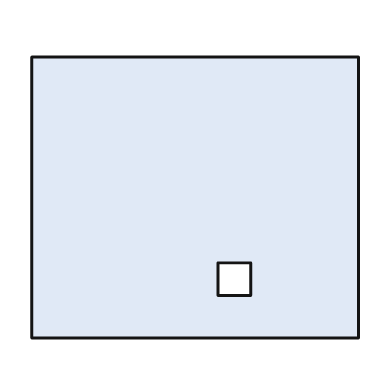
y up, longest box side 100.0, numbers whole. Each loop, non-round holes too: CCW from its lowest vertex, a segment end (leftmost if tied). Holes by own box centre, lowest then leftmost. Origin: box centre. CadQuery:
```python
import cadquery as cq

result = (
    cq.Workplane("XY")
    .moveTo(-50.0, -43.0)
    .lineTo(50.0, -43.0)
    .lineTo(50.0, 43.0)
    .lineTo(-50.0, 43.0)
    .close()
    .moveTo(7.0, -30.0)
    .lineTo(17.0, -30.0)
    .lineTo(17.0, -20.0)
    .lineTo(7.0, -20.0)
    .close()
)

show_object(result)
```